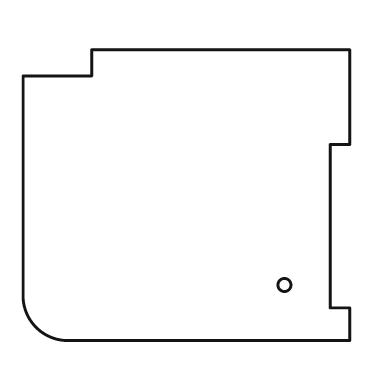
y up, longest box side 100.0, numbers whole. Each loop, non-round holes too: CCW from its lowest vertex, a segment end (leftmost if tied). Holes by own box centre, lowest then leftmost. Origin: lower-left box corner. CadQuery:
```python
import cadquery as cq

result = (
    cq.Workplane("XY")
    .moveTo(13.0, 0.0)
    .lineTo(100.0, 0.0)
    .lineTo(100.0, 10.0)
    .lineTo(94.0, 10.0)
    .lineTo(94.0, 60.0)
    .lineTo(100.0, 60.0)
    .lineTo(100.0, 89.0)
    .lineTo(21.0, 89.0)
    .lineTo(21.0, 81.0)
    .lineTo(0.0, 81.0)
    .lineTo(0.0, 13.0)
    .threePointArc((4.0, 4.0), (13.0, 0.0))
    .close()
    .moveTo(80.0, 17.0)
    .circle(2.0)
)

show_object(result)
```